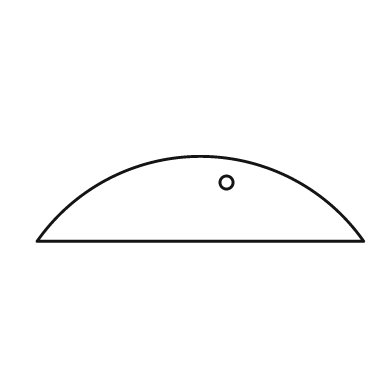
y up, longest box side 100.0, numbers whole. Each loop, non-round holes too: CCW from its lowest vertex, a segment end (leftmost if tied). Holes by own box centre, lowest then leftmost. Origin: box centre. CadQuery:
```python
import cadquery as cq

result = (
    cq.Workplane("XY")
    .moveTo(-50.0, -13.0)
    .lineTo(50.0, -13.0)
    .threePointArc((0.0, 13.0), (-50.0, -13.0))
    .close()
    .moveTo(8.0, 5.0)
    .circle(2.0)
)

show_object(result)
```